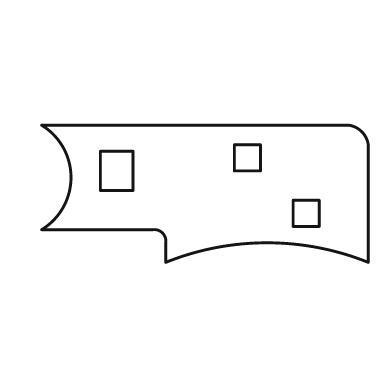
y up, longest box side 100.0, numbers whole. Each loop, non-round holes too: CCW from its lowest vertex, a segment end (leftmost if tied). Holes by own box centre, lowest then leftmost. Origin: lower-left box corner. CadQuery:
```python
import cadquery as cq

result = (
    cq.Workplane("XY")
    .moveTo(38.0, 0.0)
    .threePointArc((69.0, 6.0), (100.0, 0.0))
    .lineTo(100.0, 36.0)
    .threePointArc((98.0, 40.0), (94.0, 42.0))
    .lineTo(0.0, 42.0)
    .threePointArc((9.0, 26.0), (0.0, 10.0))
    .lineTo(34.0, 10.0)
    .threePointArc((37.0, 9.0), (38.0, 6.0))
    .close()
    .moveTo(77.0, 11.0)
    .lineTo(85.0, 11.0)
    .lineTo(85.0, 19.0)
    .lineTo(77.0, 19.0)
    .close()
    .moveTo(18.0, 22.0)
    .lineTo(28.0, 22.0)
    .lineTo(28.0, 34.0)
    .lineTo(18.0, 34.0)
    .close()
    .moveTo(59.0, 28.0)
    .lineTo(67.0, 28.0)
    .lineTo(67.0, 36.0)
    .lineTo(59.0, 36.0)
    .close()
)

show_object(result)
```